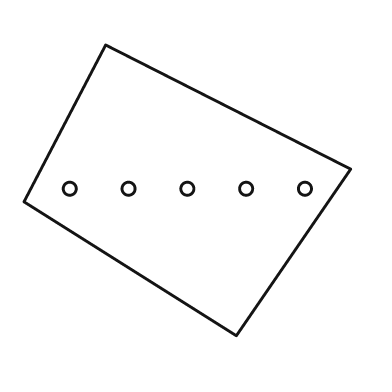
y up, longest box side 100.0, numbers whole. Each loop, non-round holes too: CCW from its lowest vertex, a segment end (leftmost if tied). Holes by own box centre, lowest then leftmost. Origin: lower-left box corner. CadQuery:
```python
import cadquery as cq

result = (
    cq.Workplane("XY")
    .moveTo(65.0, 0.0)
    .lineTo(100.0, 51.0)
    .lineTo(25.0, 89.0)
    .lineTo(0.0, 41.0)
    .close()
    .moveTo(14.0, 45.0)
    .circle(2.0)
    .moveTo(32.0, 45.0)
    .circle(2.0)
    .moveTo(50.0, 45.0)
    .circle(2.0)
    .moveTo(68.0, 45.0)
    .circle(2.0)
    .moveTo(86.0, 45.0)
    .circle(2.0)
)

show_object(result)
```